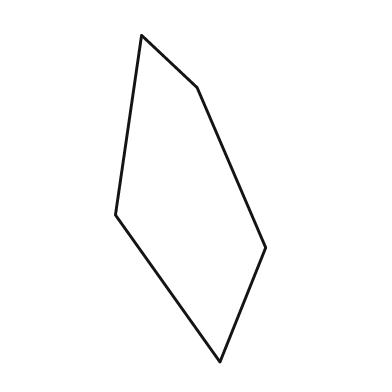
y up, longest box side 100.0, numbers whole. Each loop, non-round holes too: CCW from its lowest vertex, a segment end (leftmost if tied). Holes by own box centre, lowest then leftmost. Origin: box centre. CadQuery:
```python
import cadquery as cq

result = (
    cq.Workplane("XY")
    .moveTo(9.0, -50.0)
    .lineTo(23.0, -15.0)
    .lineTo(2.0, 34.0)
    .lineTo(-15.0, 50.0)
    .lineTo(-23.0, -5.0)
    .close()
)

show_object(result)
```